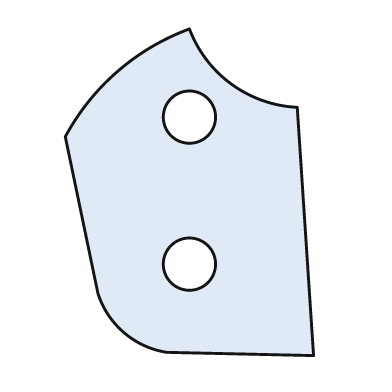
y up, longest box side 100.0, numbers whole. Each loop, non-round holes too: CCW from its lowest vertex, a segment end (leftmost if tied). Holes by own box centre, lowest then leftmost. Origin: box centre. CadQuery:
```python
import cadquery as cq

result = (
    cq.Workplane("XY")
    .moveTo(38.0, -50.0)
    .lineTo(33.0, 26.0)
    .threePointArc((13.0, 33.0), (0.0, 50.0))
    .threePointArc((-22.0, 37.0), (-38.0, 17.0))
    .lineTo(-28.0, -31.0)
    .threePointArc((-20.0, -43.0), (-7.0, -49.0))
    .close()
    .moveTo(0.0, -22.0)
    .circle(8.0)
    .moveTo(0.0, 23.0)
    .circle(8.0)
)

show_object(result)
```